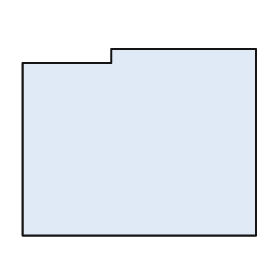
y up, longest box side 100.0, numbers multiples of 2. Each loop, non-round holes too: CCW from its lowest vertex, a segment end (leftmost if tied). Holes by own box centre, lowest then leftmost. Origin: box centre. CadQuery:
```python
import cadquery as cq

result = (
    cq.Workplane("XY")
    .moveTo(-50.0, -40.0)
    .lineTo(50.0, -40.0)
    .lineTo(50.0, 40.0)
    .lineTo(-12.0, 40.0)
    .lineTo(-12.0, 34.0)
    .lineTo(-50.0, 34.0)
    .close()
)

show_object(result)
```